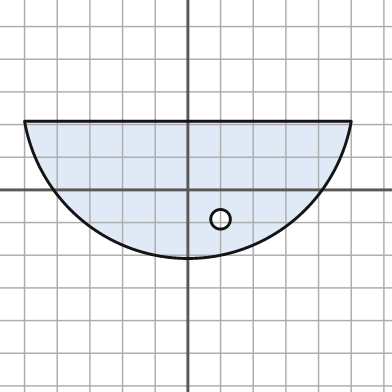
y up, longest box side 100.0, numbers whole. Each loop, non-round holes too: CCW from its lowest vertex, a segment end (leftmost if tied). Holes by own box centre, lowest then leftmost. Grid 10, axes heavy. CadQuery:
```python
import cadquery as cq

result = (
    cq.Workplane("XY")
    .moveTo(-50.0, 21.0)
    .threePointArc((0.0, -21.0), (50.0, 21.0))
    .close()
    .moveTo(10.0, -9.0)
    .circle(3.0)
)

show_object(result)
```